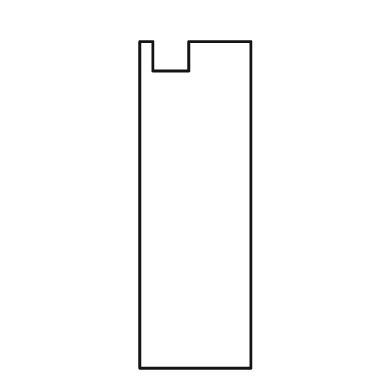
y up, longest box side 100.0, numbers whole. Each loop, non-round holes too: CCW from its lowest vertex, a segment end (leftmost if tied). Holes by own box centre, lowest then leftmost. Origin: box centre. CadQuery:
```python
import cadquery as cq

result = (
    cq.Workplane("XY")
    .moveTo(-17.0, -50.0)
    .lineTo(17.0, -50.0)
    .lineTo(17.0, 50.0)
    .lineTo(-2.0, 50.0)
    .lineTo(-2.0, 41.0)
    .lineTo(-13.0, 41.0)
    .lineTo(-13.0, 50.0)
    .lineTo(-17.0, 50.0)
    .close()
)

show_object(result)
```